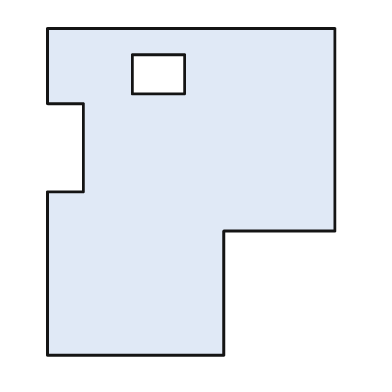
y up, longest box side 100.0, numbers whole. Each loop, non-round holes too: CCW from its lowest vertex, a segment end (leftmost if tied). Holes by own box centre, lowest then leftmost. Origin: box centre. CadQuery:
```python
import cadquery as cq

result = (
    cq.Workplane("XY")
    .moveTo(-44.0, -50.0)
    .lineTo(10.0, -50.0)
    .lineTo(10.0, -12.0)
    .lineTo(44.0, -12.0)
    .lineTo(44.0, 50.0)
    .lineTo(-44.0, 50.0)
    .lineTo(-44.0, 27.0)
    .lineTo(-33.0, 27.0)
    .lineTo(-33.0, 0.0)
    .lineTo(-44.0, 0.0)
    .close()
    .moveTo(-18.0, 30.0)
    .lineTo(-2.0, 30.0)
    .lineTo(-2.0, 42.0)
    .lineTo(-18.0, 42.0)
    .close()
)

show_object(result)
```